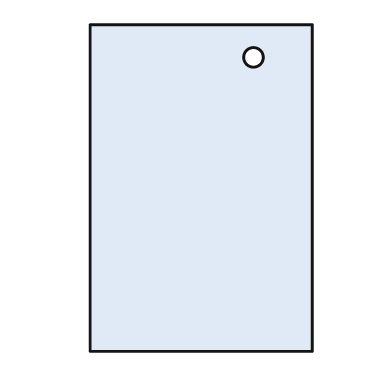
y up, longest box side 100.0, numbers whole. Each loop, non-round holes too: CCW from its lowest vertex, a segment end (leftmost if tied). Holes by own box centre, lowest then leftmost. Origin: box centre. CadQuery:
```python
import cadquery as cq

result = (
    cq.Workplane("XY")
    .moveTo(-34.0, -50.0)
    .lineTo(34.0, -50.0)
    .lineTo(34.0, 50.0)
    .lineTo(-34.0, 50.0)
    .close()
    .moveTo(16.0, 40.0)
    .circle(3.0)
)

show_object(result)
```